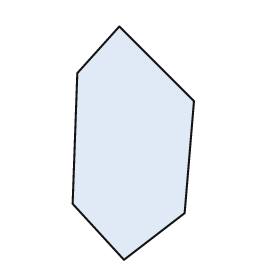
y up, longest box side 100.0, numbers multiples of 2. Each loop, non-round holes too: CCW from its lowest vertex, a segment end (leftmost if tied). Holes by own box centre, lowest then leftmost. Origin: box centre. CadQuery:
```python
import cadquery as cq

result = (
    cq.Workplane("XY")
    .moveTo(-4.0, -50.0)
    .lineTo(22.0, -30.0)
    .lineTo(26.0, 18.0)
    .lineTo(-6.0, 50.0)
    .lineTo(-24.0, 30.0)
    .lineTo(-26.0, -26.0)
    .close()
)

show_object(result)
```